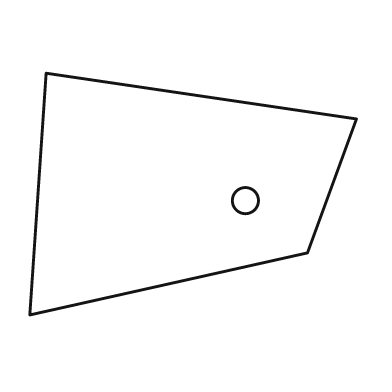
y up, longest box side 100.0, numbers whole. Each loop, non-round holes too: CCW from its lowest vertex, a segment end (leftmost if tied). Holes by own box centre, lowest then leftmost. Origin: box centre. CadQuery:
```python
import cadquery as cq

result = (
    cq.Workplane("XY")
    .moveTo(-50.0, -37.0)
    .lineTo(35.0, -18.0)
    .lineTo(50.0, 23.0)
    .lineTo(-45.0, 37.0)
    .close()
    .moveTo(16.0, -2.0)
    .circle(4.0)
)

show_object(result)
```